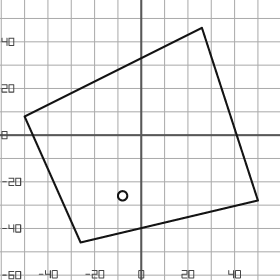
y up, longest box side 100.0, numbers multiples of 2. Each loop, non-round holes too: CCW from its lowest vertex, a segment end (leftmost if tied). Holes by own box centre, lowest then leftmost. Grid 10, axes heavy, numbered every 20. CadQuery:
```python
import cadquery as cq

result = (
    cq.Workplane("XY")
    .moveTo(-26.0, -46.0)
    .lineTo(50.0, -28.0)
    .lineTo(26.0, 46.0)
    .lineTo(-50.0, 8.0)
    .close()
    .moveTo(-8.0, -26.0)
    .circle(2.0)
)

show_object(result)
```